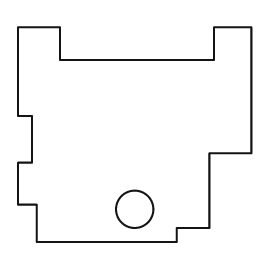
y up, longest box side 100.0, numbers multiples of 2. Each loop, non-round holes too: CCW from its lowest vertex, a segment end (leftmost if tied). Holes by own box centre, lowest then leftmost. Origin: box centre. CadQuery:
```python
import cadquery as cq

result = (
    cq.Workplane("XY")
    .moveTo(-42.0, -46.0)
    .lineTo(18.0, -46.0)
    .lineTo(18.0, -40.0)
    .lineTo(32.0, -40.0)
    .lineTo(32.0, -8.0)
    .lineTo(50.0, -8.0)
    .lineTo(50.0, 46.0)
    .lineTo(34.0, 46.0)
    .lineTo(34.0, 32.0)
    .lineTo(-32.0, 32.0)
    .lineTo(-32.0, 46.0)
    .lineTo(-50.0, 46.0)
    .lineTo(-50.0, 8.0)
    .lineTo(-44.0, 8.0)
    .lineTo(-44.0, -12.0)
    .lineTo(-50.0, -12.0)
    .lineTo(-50.0, -30.0)
    .lineTo(-42.0, -30.0)
    .close()
    .moveTo(0.0, -32.0)
    .circle(8.0)
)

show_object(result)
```